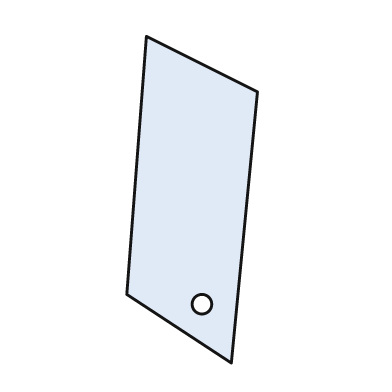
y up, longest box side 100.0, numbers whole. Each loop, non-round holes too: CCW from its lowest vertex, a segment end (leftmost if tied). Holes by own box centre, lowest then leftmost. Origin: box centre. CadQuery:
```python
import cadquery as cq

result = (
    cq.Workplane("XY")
    .moveTo(12.0, -50.0)
    .lineTo(20.0, 33.0)
    .lineTo(-14.0, 50.0)
    .lineTo(-20.0, -29.0)
    .close()
    .moveTo(3.0, -32.0)
    .circle(3.0)
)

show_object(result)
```